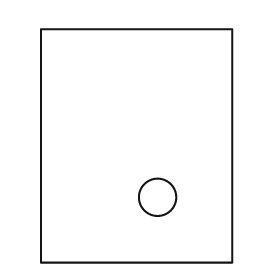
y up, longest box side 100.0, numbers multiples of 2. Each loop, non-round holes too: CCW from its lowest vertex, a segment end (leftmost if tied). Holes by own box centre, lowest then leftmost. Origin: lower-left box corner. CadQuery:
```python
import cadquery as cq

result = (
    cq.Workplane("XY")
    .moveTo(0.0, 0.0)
    .lineTo(82.0, 0.0)
    .lineTo(82.0, 100.0)
    .lineTo(0.0, 100.0)
    .close()
    .moveTo(50.0, 28.0)
    .circle(8.0)
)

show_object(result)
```